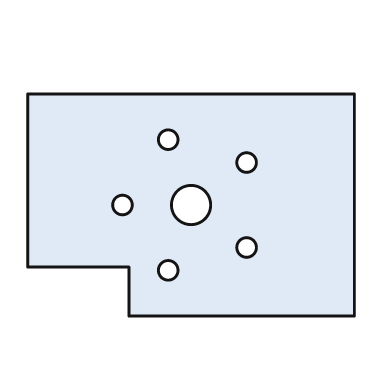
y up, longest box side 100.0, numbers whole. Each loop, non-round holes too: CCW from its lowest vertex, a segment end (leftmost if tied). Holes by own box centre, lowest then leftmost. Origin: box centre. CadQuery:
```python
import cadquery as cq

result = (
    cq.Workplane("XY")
    .moveTo(-19.0, -34.0)
    .lineTo(50.0, -34.0)
    .lineTo(50.0, 34.0)
    .lineTo(-50.0, 34.0)
    .lineTo(-50.0, -19.0)
    .lineTo(-19.0, -19.0)
    .close()
    .moveTo(-7.0, -20.0)
    .circle(3.0)
    .moveTo(17.0, -13.0)
    .circle(3.0)
    .moveTo(-21.0, 0.0)
    .circle(3.0)
    .moveTo(0.0, 0.0)
    .circle(6.0)
    .moveTo(17.0, 13.0)
    .circle(3.0)
    .moveTo(-7.0, 20.0)
    .circle(3.0)
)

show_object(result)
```